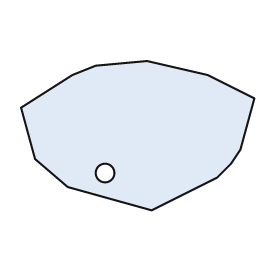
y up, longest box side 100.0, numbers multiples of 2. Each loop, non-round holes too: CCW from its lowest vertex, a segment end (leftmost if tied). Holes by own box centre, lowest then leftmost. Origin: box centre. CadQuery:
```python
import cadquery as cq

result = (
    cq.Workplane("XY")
    .moveTo(6.0, -32.0)
    .lineTo(34.0, -18.0)
    .lineTo(40.0, -12.0)
    .lineTo(44.0, -6.0)
    .lineTo(50.0, 16.0)
    .lineTo(30.0, 26.0)
    .lineTo(4.0, 32.0)
    .lineTo(-18.0, 30.0)
    .lineTo(-28.0, 26.0)
    .lineTo(-50.0, 12.0)
    .lineTo(-44.0, -10.0)
    .lineTo(-30.0, -22.0)
    .close()
    .moveTo(-14.0, -16.0)
    .circle(4.0)
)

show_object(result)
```